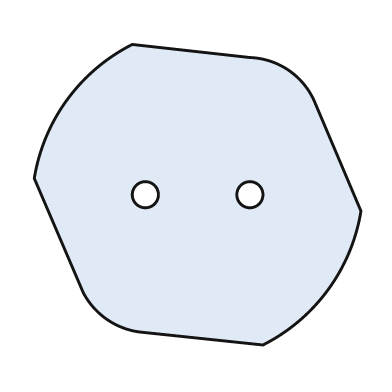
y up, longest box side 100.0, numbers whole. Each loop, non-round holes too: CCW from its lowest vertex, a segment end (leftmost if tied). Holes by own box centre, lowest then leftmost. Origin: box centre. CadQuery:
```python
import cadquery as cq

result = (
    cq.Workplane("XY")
    .moveTo(20.0, -46.0)
    .threePointArc((40.0, -29.0), (50.0, -5.0))
    .lineTo(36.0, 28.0)
    .threePointArc((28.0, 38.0), (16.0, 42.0))
    .lineTo(-20.0, 46.0)
    .threePointArc((-40.0, 29.0), (-50.0, 5.0))
    .lineTo(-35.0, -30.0)
    .threePointArc((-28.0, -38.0), (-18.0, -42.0))
    .close()
    .moveTo(-16.0, 0.0)
    .circle(4.0)
    .moveTo(16.0, 0.0)
    .circle(4.0)
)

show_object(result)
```